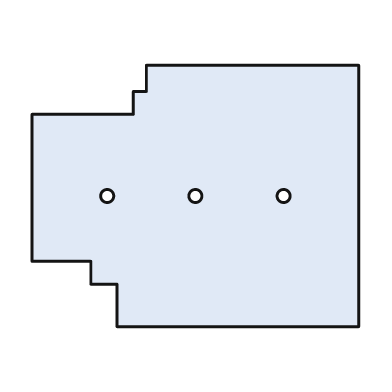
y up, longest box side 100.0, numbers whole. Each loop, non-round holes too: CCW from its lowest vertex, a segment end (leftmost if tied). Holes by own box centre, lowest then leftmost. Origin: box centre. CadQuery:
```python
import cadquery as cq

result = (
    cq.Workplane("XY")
    .moveTo(-24.0, -40.0)
    .lineTo(50.0, -40.0)
    .lineTo(50.0, 40.0)
    .lineTo(-15.0, 40.0)
    .lineTo(-15.0, 32.0)
    .lineTo(-19.0, 32.0)
    .lineTo(-19.0, 25.0)
    .lineTo(-50.0, 25.0)
    .lineTo(-50.0, -20.0)
    .lineTo(-32.0, -20.0)
    .lineTo(-32.0, -27.0)
    .lineTo(-24.0, -27.0)
    .close()
    .moveTo(-27.0, 0.0)
    .circle(2.0)
    .moveTo(0.0, 0.0)
    .circle(2.0)
    .moveTo(27.0, 0.0)
    .circle(2.0)
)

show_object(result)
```